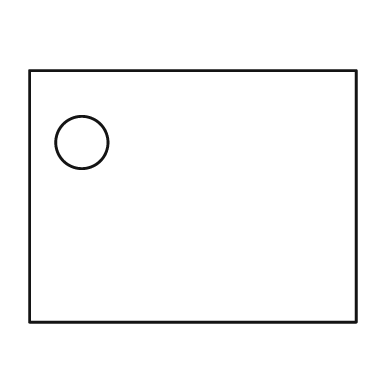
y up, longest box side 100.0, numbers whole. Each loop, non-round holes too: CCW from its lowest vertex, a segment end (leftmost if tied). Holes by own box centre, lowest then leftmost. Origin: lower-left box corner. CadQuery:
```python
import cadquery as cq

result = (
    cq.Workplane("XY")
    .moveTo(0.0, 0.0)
    .lineTo(100.0, 0.0)
    .lineTo(100.0, 77.0)
    .lineTo(0.0, 77.0)
    .close()
    .moveTo(16.0, 55.0)
    .circle(8.0)
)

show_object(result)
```